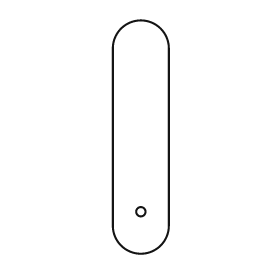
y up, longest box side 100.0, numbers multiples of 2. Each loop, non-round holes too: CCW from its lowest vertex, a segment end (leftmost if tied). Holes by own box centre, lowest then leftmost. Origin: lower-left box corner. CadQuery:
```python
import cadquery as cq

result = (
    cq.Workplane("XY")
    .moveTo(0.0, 12.0)
    .threePointArc((12.0, 0.0), (24.0, 12.0))
    .lineTo(24.0, 88.0)
    .threePointArc((12.0, 100.0), (0.0, 88.0))
    .close()
    .moveTo(12.0, 18.0)
    .circle(2.0)
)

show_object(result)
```